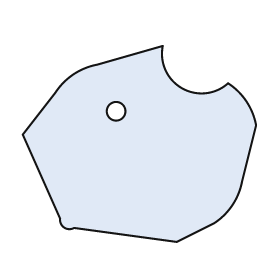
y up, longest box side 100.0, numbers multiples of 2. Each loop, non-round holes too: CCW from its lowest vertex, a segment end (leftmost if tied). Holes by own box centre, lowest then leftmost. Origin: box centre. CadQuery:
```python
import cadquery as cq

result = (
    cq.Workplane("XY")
    .moveTo(16.0, -42.0)
    .lineTo(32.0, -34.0)
    .threePointArc((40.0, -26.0), (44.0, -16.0))
    .lineTo(50.0, 8.0)
    .threePointArc((46.0, 18.0), (38.0, 26.0))
    .threePointArc((18.0, 24.0), (10.0, 42.0))
    .lineTo(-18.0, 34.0)
    .threePointArc((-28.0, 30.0), (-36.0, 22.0))
    .lineTo(-50.0, 4.0)
    .lineTo(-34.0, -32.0)
    .threePointArc((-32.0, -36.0), (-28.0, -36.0))
    .close()
    .moveTo(-10.0, 14.0)
    .circle(4.0)
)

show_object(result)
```